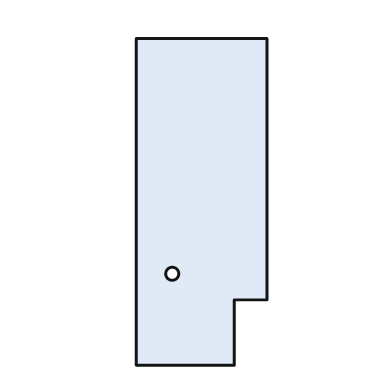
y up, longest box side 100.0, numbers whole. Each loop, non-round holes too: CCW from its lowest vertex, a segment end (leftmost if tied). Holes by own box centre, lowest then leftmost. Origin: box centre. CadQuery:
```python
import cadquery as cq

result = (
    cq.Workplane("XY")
    .moveTo(-20.0, -50.0)
    .lineTo(10.0, -50.0)
    .lineTo(10.0, -30.0)
    .lineTo(20.0, -30.0)
    .lineTo(20.0, 50.0)
    .lineTo(-20.0, 50.0)
    .close()
    .moveTo(-9.0, -22.0)
    .circle(2.0)
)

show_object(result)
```